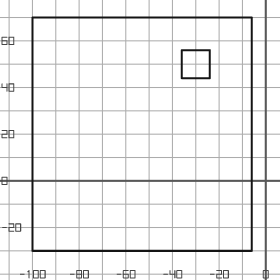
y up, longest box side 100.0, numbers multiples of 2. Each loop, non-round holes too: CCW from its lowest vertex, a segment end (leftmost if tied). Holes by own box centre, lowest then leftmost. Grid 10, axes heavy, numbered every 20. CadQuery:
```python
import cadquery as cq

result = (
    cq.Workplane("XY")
    .moveTo(-100.0, -30.0)
    .lineTo(-6.0, -30.0)
    .lineTo(-6.0, 70.0)
    .lineTo(-100.0, 70.0)
    .close()
    .moveTo(-36.0, 44.0)
    .lineTo(-24.0, 44.0)
    .lineTo(-24.0, 56.0)
    .lineTo(-36.0, 56.0)
    .close()
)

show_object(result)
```